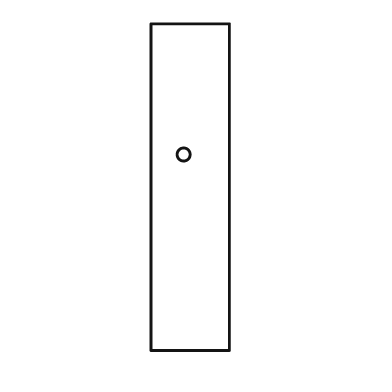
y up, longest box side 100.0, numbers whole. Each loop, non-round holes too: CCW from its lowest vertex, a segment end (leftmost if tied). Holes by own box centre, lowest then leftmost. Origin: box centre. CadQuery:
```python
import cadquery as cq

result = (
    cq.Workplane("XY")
    .moveTo(-12.0, -50.0)
    .lineTo(12.0, -50.0)
    .lineTo(12.0, 50.0)
    .lineTo(-12.0, 50.0)
    .close()
    .moveTo(-2.0, 10.0)
    .circle(2.0)
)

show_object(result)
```